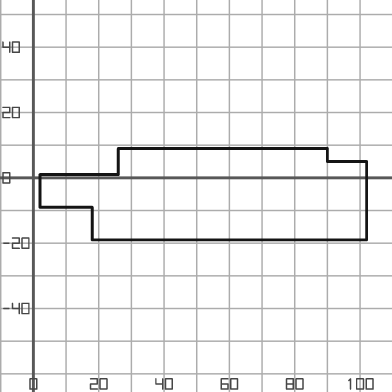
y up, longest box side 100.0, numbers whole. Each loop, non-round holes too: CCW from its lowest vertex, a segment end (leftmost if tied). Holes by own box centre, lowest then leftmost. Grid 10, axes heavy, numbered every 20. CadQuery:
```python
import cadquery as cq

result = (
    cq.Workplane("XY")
    .moveTo(18.0, -19.0)
    .lineTo(102.0, -19.0)
    .lineTo(102.0, 5.0)
    .lineTo(90.0, 5.0)
    .lineTo(90.0, 9.0)
    .lineTo(26.0, 9.0)
    .lineTo(26.0, 1.0)
    .lineTo(2.0, 1.0)
    .lineTo(2.0, -9.0)
    .lineTo(18.0, -9.0)
    .close()
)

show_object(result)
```